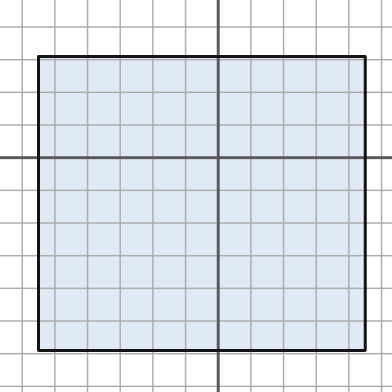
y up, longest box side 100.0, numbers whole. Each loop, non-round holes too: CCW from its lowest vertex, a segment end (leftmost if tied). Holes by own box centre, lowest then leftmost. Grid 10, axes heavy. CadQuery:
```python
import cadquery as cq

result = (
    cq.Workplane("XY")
    .moveTo(-55.0, -59.0)
    .lineTo(45.0, -59.0)
    .lineTo(45.0, 31.0)
    .lineTo(-55.0, 31.0)
    .close()
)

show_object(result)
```